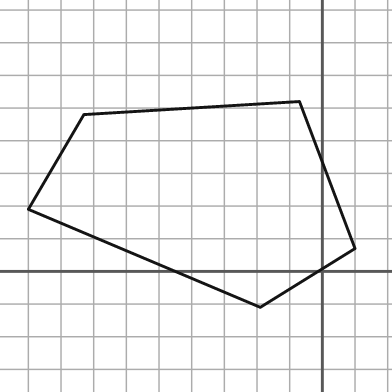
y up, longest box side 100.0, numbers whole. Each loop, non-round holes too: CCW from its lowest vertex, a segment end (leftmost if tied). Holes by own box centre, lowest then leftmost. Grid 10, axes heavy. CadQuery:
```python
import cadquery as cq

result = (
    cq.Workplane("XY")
    .moveTo(-19.0, -11.0)
    .lineTo(10.0, 7.0)
    .lineTo(-7.0, 52.0)
    .lineTo(-73.0, 48.0)
    .lineTo(-90.0, 19.0)
    .close()
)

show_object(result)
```